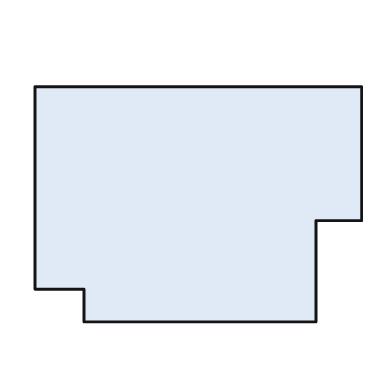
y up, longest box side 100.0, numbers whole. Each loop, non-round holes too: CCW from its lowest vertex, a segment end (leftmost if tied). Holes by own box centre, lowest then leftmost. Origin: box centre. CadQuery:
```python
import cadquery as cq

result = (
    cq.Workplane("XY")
    .moveTo(-35.0, -36.0)
    .lineTo(36.0, -36.0)
    .lineTo(36.0, -5.0)
    .lineTo(50.0, -5.0)
    .lineTo(50.0, 36.0)
    .lineTo(-50.0, 36.0)
    .lineTo(-50.0, -26.0)
    .lineTo(-35.0, -26.0)
    .close()
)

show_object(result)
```